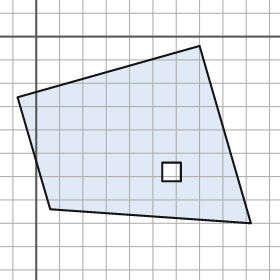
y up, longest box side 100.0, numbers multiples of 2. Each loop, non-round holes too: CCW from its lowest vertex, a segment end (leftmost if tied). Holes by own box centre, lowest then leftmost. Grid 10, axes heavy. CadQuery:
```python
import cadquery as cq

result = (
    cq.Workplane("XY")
    .moveTo(92.0, -80.0)
    .lineTo(70.0, -4.0)
    .lineTo(-8.0, -26.0)
    .lineTo(6.0, -74.0)
    .close()
    .moveTo(54.0, -62.0)
    .lineTo(62.0, -62.0)
    .lineTo(62.0, -54.0)
    .lineTo(54.0, -54.0)
    .close()
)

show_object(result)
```